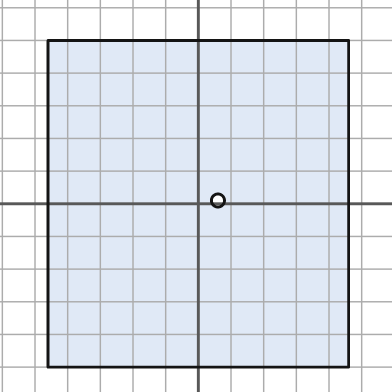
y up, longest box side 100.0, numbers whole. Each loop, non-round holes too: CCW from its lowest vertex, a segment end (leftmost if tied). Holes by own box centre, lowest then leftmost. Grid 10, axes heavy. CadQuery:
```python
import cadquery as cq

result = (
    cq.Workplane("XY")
    .moveTo(-46.0, -50.0)
    .lineTo(46.0, -50.0)
    .lineTo(46.0, 50.0)
    .lineTo(-46.0, 50.0)
    .close()
    .moveTo(6.0, 1.0)
    .circle(2.0)
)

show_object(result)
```